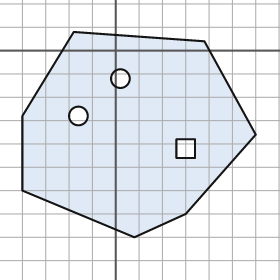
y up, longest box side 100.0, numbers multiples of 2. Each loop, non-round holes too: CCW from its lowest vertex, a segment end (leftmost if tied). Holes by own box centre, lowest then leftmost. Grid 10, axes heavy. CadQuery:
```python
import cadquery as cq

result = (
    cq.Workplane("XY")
    .moveTo(8.0, -80.0)
    .lineTo(30.0, -70.0)
    .lineTo(60.0, -36.0)
    .lineTo(38.0, 4.0)
    .lineTo(-18.0, 8.0)
    .lineTo(-40.0, -28.0)
    .lineTo(-40.0, -60.0)
    .close()
    .moveTo(26.0, -46.0)
    .lineTo(34.0, -46.0)
    .lineTo(34.0, -38.0)
    .lineTo(26.0, -38.0)
    .close()
    .moveTo(-16.0, -28.0)
    .circle(4.0)
    .moveTo(2.0, -12.0)
    .circle(4.0)
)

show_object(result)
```